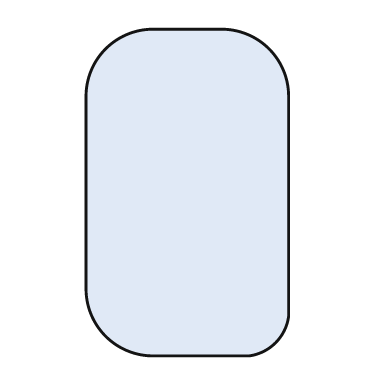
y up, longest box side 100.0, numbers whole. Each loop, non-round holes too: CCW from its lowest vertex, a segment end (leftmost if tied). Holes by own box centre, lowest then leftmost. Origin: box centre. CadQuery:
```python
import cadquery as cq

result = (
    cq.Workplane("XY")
    .moveTo(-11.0, -50.0)
    .lineTo(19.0, -50.0)
    .threePointArc((27.0, -46.0), (31.0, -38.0))
    .lineTo(31.0, 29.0)
    .threePointArc((25.0, 44.0), (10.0, 50.0))
    .lineTo(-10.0, 50.0)
    .threePointArc((-25.0, 44.0), (-31.0, 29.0))
    .lineTo(-31.0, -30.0)
    .threePointArc((-25.0, -44.0), (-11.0, -50.0))
    .close()
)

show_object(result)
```